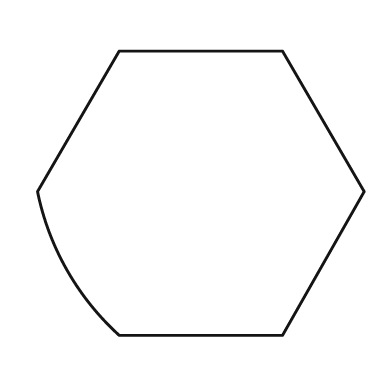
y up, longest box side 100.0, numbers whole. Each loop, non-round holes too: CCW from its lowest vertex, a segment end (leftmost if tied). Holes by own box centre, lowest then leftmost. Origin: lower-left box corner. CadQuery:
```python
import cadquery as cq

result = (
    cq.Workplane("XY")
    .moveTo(25.0, 0.0)
    .lineTo(75.0, 0.0)
    .lineTo(100.0, 44.0)
    .lineTo(75.0, 87.0)
    .lineTo(25.0, 87.0)
    .lineTo(0.0, 44.0)
    .threePointArc((9.0, 20.0), (25.0, 0.0))
    .close()
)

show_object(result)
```